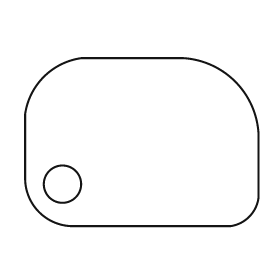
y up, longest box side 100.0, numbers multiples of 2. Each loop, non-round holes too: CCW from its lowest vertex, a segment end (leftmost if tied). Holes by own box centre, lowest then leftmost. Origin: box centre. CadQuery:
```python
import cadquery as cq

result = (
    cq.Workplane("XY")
    .moveTo(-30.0, -36.0)
    .lineTo(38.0, -36.0)
    .threePointArc((46.0, -32.0), (50.0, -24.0))
    .lineTo(50.0, 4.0)
    .threePointArc((40.0, 26.0), (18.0, 36.0))
    .lineTo(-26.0, 36.0)
    .threePointArc((-42.0, 28.0), (-50.0, 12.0))
    .lineTo(-50.0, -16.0)
    .threePointArc((-44.0, -30.0), (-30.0, -36.0))
    .close()
    .moveTo(-34.0, -18.0)
    .circle(8.0)
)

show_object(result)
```